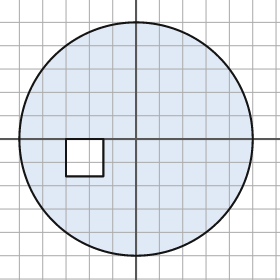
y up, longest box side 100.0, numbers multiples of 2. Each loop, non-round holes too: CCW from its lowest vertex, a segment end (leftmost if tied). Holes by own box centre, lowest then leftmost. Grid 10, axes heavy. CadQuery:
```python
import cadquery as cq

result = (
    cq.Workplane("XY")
    .moveTo(0.0, 0.0)
    .circle(50.0)
    .moveTo(-30.0, -16.0)
    .lineTo(-14.0, -16.0)
    .lineTo(-14.0, 0.0)
    .lineTo(-30.0, 0.0)
    .close()
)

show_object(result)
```